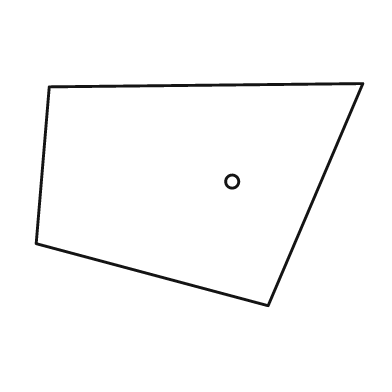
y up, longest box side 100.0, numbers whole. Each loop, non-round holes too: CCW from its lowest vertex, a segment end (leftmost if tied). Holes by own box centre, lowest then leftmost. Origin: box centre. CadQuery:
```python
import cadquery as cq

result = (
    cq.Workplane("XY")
    .moveTo(21.0, -34.0)
    .lineTo(50.0, 34.0)
    .lineTo(-46.0, 33.0)
    .lineTo(-50.0, -15.0)
    .close()
    .moveTo(10.0, 4.0)
    .circle(2.0)
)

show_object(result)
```